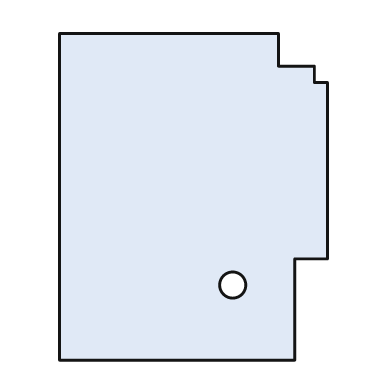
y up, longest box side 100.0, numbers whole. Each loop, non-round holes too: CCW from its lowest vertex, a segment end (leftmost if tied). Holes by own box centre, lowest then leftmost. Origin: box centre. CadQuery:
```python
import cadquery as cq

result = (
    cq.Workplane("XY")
    .moveTo(-41.0, -50.0)
    .lineTo(31.0, -50.0)
    .lineTo(31.0, -19.0)
    .lineTo(41.0, -19.0)
    .lineTo(41.0, 35.0)
    .lineTo(37.0, 35.0)
    .lineTo(37.0, 40.0)
    .lineTo(26.0, 40.0)
    .lineTo(26.0, 50.0)
    .lineTo(-41.0, 50.0)
    .close()
    .moveTo(12.0, -27.0)
    .circle(4.0)
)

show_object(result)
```